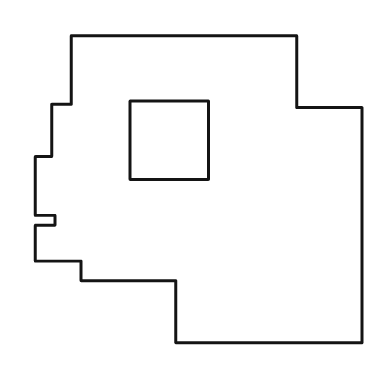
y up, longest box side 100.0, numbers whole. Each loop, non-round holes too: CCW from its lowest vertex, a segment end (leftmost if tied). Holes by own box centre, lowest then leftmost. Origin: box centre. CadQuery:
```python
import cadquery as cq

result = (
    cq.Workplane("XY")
    .moveTo(-7.0, -47.0)
    .lineTo(50.0, -47.0)
    .lineTo(50.0, 25.0)
    .lineTo(30.0, 25.0)
    .lineTo(30.0, 47.0)
    .lineTo(-39.0, 47.0)
    .lineTo(-39.0, 26.0)
    .lineTo(-45.0, 26.0)
    .lineTo(-45.0, 10.0)
    .lineTo(-50.0, 10.0)
    .lineTo(-50.0, -8.0)
    .lineTo(-44.0, -8.0)
    .lineTo(-44.0, -11.0)
    .lineTo(-50.0, -11.0)
    .lineTo(-50.0, -22.0)
    .lineTo(-36.0, -22.0)
    .lineTo(-36.0, -28.0)
    .lineTo(-7.0, -28.0)
    .close()
    .moveTo(-21.0, 3.0)
    .lineTo(3.0, 3.0)
    .lineTo(3.0, 27.0)
    .lineTo(-21.0, 27.0)
    .close()
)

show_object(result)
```